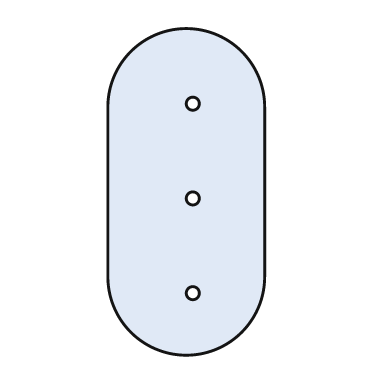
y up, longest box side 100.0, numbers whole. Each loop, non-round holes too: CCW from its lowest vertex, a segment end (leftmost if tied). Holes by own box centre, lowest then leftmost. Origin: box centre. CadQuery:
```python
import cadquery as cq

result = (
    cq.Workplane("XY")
    .moveTo(-24.0, -26.0)
    .threePointArc((0.0, -50.0), (24.0, -26.0))
    .lineTo(24.0, 26.0)
    .threePointArc((0.0, 50.0), (-24.0, 26.0))
    .close()
    .moveTo(2.0, -31.0)
    .circle(2.0)
    .moveTo(2.0, -2.0)
    .circle(2.0)
    .moveTo(2.0, 27.0)
    .circle(2.0)
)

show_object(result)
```